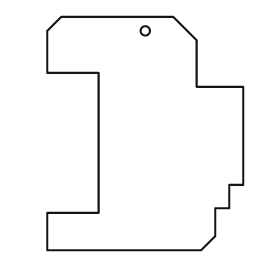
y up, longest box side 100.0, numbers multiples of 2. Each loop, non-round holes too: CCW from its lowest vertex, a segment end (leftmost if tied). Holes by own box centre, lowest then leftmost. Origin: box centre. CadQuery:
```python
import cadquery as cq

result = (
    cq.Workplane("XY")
    .moveTo(-42.0, -50.0)
    .lineTo(24.0, -50.0)
    .lineTo(30.0, -44.0)
    .lineTo(30.0, -32.0)
    .lineTo(36.0, -32.0)
    .lineTo(36.0, -22.0)
    .lineTo(42.0, -22.0)
    .lineTo(42.0, 20.0)
    .lineTo(22.0, 20.0)
    .lineTo(22.0, 40.0)
    .lineTo(12.0, 50.0)
    .lineTo(-36.0, 50.0)
    .lineTo(-42.0, 44.0)
    .lineTo(-42.0, 26.0)
    .lineTo(-20.0, 26.0)
    .lineTo(-20.0, -34.0)
    .lineTo(-42.0, -34.0)
    .close()
    .moveTo(0.0, 44.0)
    .circle(2.0)
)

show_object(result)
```